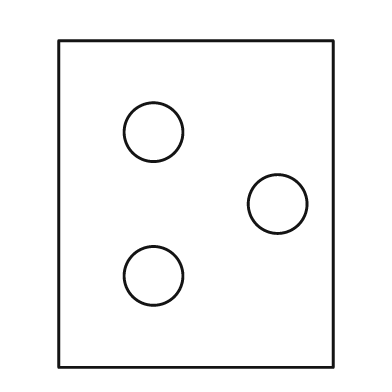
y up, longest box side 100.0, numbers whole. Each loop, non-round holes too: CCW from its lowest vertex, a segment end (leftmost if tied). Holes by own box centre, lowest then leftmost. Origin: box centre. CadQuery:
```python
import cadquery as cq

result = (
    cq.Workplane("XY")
    .moveTo(-42.0, -50.0)
    .lineTo(42.0, -50.0)
    .lineTo(42.0, 50.0)
    .lineTo(-42.0, 50.0)
    .close()
    .moveTo(-13.0, -22.0)
    .circle(9.0)
    .moveTo(25.0, 0.0)
    .circle(9.0)
    .moveTo(-13.0, 22.0)
    .circle(9.0)
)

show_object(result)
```